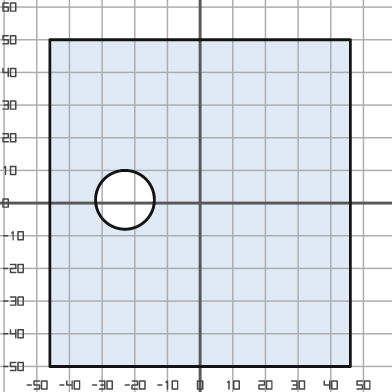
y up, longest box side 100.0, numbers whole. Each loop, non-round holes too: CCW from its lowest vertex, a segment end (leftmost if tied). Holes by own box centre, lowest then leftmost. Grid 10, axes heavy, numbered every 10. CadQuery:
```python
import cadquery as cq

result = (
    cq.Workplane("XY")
    .moveTo(-46.0, -50.0)
    .lineTo(46.0, -50.0)
    .lineTo(46.0, 50.0)
    .lineTo(-46.0, 50.0)
    .close()
    .moveTo(-23.0, 1.0)
    .circle(9.0)
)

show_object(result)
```